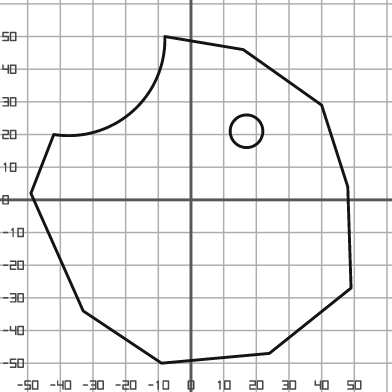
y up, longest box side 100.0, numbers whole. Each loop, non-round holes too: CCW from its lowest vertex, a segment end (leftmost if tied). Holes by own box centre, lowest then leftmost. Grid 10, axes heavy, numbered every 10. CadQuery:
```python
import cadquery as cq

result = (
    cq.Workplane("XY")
    .moveTo(-9.0, -50.0)
    .lineTo(24.0, -47.0)
    .lineTo(49.0, -27.0)
    .lineTo(48.0, 4.0)
    .lineTo(40.0, 29.0)
    .lineTo(16.0, 46.0)
    .lineTo(-8.0, 50.0)
    .threePointArc((-18.0, 27.0), (-42.0, 20.0))
    .lineTo(-49.0, 2.0)
    .lineTo(-33.0, -34.0)
    .close()
    .moveTo(17.0, 21.0)
    .circle(5.0)
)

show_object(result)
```